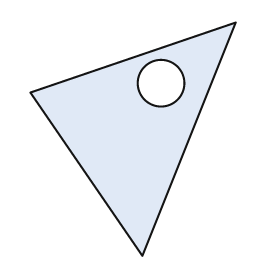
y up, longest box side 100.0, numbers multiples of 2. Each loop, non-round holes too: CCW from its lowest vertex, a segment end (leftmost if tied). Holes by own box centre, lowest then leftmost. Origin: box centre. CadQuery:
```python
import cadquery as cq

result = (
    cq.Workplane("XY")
    .moveTo(4.0, -50.0)
    .lineTo(44.0, 50.0)
    .lineTo(-44.0, 20.0)
    .close()
    .moveTo(12.0, 24.0)
    .circle(10.0)
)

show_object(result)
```